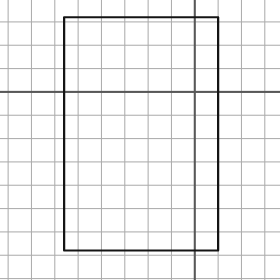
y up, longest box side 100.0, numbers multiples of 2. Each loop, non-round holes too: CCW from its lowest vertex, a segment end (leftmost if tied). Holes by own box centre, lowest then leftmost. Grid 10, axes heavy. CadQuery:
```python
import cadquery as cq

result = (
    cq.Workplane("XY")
    .moveTo(-56.0, -68.0)
    .lineTo(10.0, -68.0)
    .lineTo(10.0, 32.0)
    .lineTo(-56.0, 32.0)
    .close()
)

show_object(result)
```